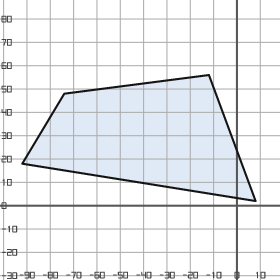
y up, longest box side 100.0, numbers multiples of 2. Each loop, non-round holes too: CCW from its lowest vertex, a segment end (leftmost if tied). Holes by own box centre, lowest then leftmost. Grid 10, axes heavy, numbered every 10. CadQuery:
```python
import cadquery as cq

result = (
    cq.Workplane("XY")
    .moveTo(8.0, 2.0)
    .lineTo(-12.0, 56.0)
    .lineTo(-74.0, 48.0)
    .lineTo(-92.0, 18.0)
    .close()
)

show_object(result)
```